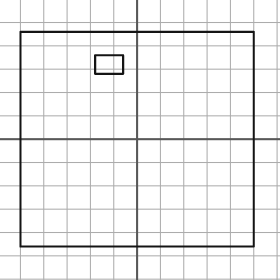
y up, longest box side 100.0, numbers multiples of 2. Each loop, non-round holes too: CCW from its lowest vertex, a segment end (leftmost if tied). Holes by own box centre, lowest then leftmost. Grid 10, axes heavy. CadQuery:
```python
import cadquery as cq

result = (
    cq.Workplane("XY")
    .moveTo(-50.0, -46.0)
    .lineTo(50.0, -46.0)
    .lineTo(50.0, 46.0)
    .lineTo(-50.0, 46.0)
    .close()
    .moveTo(-18.0, 28.0)
    .lineTo(-6.0, 28.0)
    .lineTo(-6.0, 36.0)
    .lineTo(-18.0, 36.0)
    .close()
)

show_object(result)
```